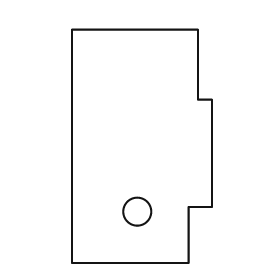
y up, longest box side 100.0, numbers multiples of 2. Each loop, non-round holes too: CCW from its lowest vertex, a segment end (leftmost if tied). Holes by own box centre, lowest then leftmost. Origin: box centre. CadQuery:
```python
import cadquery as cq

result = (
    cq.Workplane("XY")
    .moveTo(-30.0, -50.0)
    .lineTo(20.0, -50.0)
    .lineTo(20.0, -26.0)
    .lineTo(30.0, -26.0)
    .lineTo(30.0, 20.0)
    .lineTo(24.0, 20.0)
    .lineTo(24.0, 50.0)
    .lineTo(-30.0, 50.0)
    .close()
    .moveTo(-2.0, -28.0)
    .circle(6.0)
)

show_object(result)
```